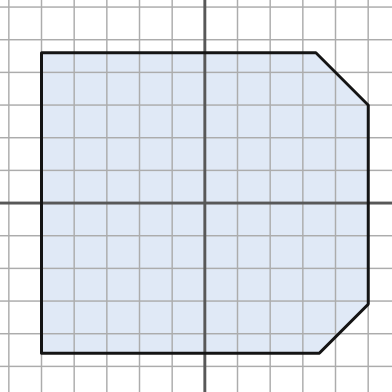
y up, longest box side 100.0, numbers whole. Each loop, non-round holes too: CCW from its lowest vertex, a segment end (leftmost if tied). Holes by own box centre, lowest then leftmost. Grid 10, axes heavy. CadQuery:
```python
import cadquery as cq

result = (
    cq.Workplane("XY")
    .moveTo(-50.0, -46.0)
    .lineTo(35.0, -46.0)
    .lineTo(50.0, -31.0)
    .lineTo(50.0, 30.0)
    .lineTo(34.0, 46.0)
    .lineTo(-50.0, 46.0)
    .close()
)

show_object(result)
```